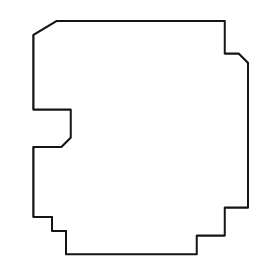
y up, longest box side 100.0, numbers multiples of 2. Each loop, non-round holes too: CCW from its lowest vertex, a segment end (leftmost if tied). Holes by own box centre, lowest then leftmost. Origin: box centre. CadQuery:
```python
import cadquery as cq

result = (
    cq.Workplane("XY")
    .moveTo(-32.0, -50.0)
    .lineTo(24.0, -50.0)
    .lineTo(24.0, -42.0)
    .lineTo(36.0, -42.0)
    .lineTo(36.0, -30.0)
    .lineTo(46.0, -30.0)
    .lineTo(46.0, 32.0)
    .lineTo(42.0, 36.0)
    .lineTo(36.0, 36.0)
    .lineTo(36.0, 50.0)
    .lineTo(-36.0, 50.0)
    .lineTo(-46.0, 44.0)
    .lineTo(-46.0, 12.0)
    .lineTo(-30.0, 12.0)
    .lineTo(-30.0, 0.0)
    .lineTo(-34.0, -4.0)
    .lineTo(-46.0, -4.0)
    .lineTo(-46.0, -34.0)
    .lineTo(-38.0, -34.0)
    .lineTo(-38.0, -40.0)
    .lineTo(-32.0, -40.0)
    .close()
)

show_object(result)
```